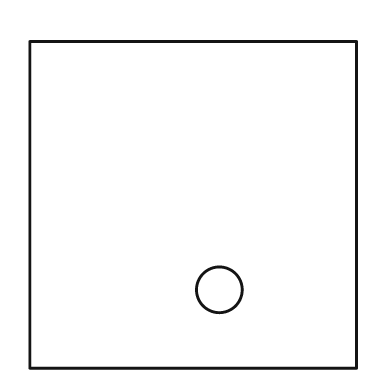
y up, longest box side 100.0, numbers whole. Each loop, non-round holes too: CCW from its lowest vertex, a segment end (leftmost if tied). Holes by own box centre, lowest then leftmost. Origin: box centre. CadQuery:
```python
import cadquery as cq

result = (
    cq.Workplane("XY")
    .moveTo(-50.0, -50.0)
    .lineTo(50.0, -50.0)
    .lineTo(50.0, 50.0)
    .lineTo(-50.0, 50.0)
    .close()
    .moveTo(8.0, -26.0)
    .circle(7.0)
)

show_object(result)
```